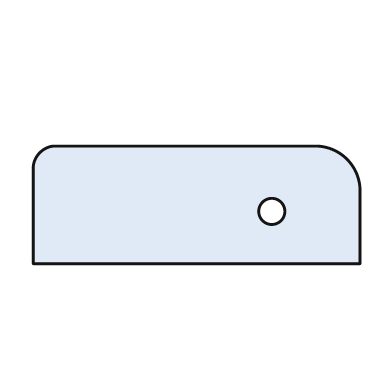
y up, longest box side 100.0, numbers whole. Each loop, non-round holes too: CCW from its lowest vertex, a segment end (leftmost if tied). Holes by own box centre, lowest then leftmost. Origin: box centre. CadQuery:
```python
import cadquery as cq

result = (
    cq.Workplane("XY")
    .moveTo(-50.0, -18.0)
    .lineTo(50.0, -18.0)
    .lineTo(50.0, 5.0)
    .threePointArc((46.0, 14.0), (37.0, 18.0))
    .lineTo(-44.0, 18.0)
    .threePointArc((-48.0, 16.0), (-50.0, 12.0))
    .close()
    .moveTo(23.0, -2.0)
    .circle(4.0)
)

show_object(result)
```